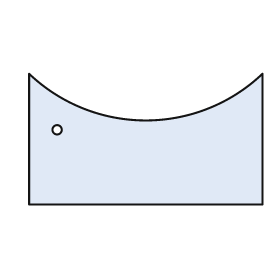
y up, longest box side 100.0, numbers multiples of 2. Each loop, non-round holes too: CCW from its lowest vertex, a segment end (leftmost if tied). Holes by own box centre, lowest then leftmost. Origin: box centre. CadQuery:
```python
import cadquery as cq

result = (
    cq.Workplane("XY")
    .moveTo(-50.0, -28.0)
    .lineTo(50.0, -28.0)
    .lineTo(50.0, 28.0)
    .threePointArc((0.0, 8.0), (-50.0, 28.0))
    .close()
    .moveTo(-38.0, 4.0)
    .circle(2.0)
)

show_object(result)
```